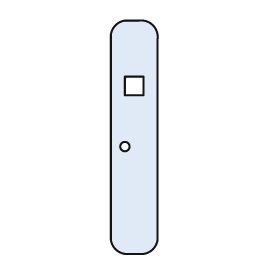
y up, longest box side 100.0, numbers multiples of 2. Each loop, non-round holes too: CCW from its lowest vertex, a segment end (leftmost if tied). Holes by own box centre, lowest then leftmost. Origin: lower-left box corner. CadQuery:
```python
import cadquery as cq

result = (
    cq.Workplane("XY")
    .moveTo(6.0, 0.0)
    .lineTo(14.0, 0.0)
    .threePointArc((18.0, 2.0), (20.0, 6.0))
    .lineTo(20.0, 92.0)
    .threePointArc((18.0, 98.0), (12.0, 100.0))
    .lineTo(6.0, 100.0)
    .threePointArc((2.0, 98.0), (0.0, 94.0))
    .lineTo(0.0, 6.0)
    .threePointArc((2.0, 2.0), (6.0, 0.0))
    .close()
    .moveTo(6.0, 46.0)
    .circle(2.0)
    .moveTo(6.0, 68.0)
    .lineTo(14.0, 68.0)
    .lineTo(14.0, 76.0)
    .lineTo(6.0, 76.0)
    .close()
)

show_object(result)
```